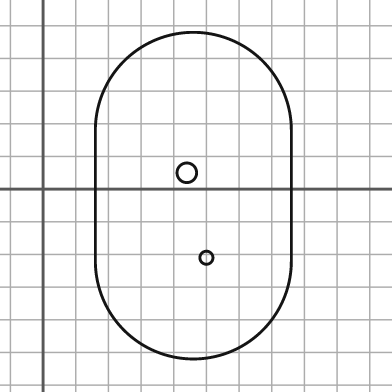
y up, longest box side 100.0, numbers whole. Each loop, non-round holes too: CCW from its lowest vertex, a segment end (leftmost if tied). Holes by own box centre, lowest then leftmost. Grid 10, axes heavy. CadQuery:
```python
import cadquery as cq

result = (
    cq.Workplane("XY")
    .moveTo(16.0, -22.0)
    .threePointArc((46.0, -52.0), (76.0, -22.0))
    .lineTo(76.0, 18.0)
    .threePointArc((46.0, 48.0), (16.0, 18.0))
    .close()
    .moveTo(50.0, -21.0)
    .circle(2.0)
    .moveTo(44.0, 5.0)
    .circle(3.0)
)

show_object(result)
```